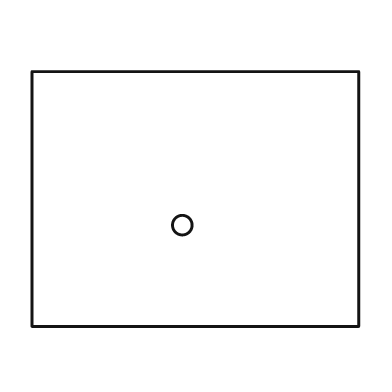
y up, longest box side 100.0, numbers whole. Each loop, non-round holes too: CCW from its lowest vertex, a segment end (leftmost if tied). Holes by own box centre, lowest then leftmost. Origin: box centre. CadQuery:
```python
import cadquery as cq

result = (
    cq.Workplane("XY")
    .moveTo(-50.0, -39.0)
    .lineTo(50.0, -39.0)
    .lineTo(50.0, 39.0)
    .lineTo(-50.0, 39.0)
    .close()
    .moveTo(-4.0, -8.0)
    .circle(3.0)
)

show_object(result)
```